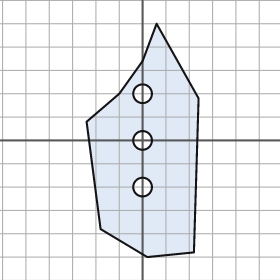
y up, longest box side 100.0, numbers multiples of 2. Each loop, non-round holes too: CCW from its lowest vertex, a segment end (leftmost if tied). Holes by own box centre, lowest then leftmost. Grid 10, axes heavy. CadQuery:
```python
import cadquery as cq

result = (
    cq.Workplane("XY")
    .moveTo(2.0, -50.0)
    .lineTo(22.0, -48.0)
    .lineTo(24.0, 18.0)
    .lineTo(6.0, 50.0)
    .lineTo(0.0, 34.0)
    .lineTo(-10.0, 20.0)
    .lineTo(-24.0, 8.0)
    .lineTo(-18.0, -38.0)
    .close()
    .moveTo(0.0, -20.0)
    .circle(4.0)
    .moveTo(0.0, 0.0)
    .circle(4.0)
    .moveTo(0.0, 20.0)
    .circle(4.0)
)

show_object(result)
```